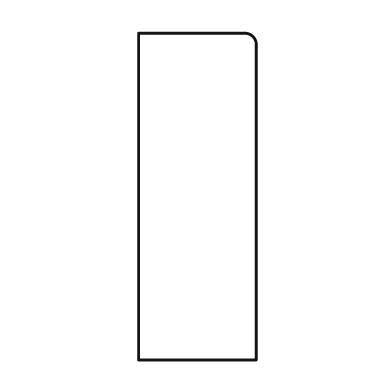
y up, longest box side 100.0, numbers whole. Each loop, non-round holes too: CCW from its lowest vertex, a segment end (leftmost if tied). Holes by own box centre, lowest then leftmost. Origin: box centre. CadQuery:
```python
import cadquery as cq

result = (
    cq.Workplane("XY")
    .moveTo(-18.0, -50.0)
    .lineTo(18.0, -50.0)
    .lineTo(18.0, 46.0)
    .threePointArc((17.0, 49.0), (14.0, 50.0))
    .lineTo(-18.0, 50.0)
    .close()
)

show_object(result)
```